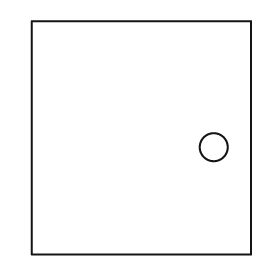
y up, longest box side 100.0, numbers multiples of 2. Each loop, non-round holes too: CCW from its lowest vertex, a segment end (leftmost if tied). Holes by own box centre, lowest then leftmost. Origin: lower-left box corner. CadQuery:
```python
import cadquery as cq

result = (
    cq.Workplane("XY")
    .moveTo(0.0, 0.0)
    .lineTo(94.0, 0.0)
    .lineTo(94.0, 100.0)
    .lineTo(0.0, 100.0)
    .close()
    .moveTo(78.0, 46.0)
    .circle(6.0)
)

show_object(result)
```